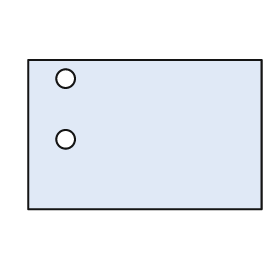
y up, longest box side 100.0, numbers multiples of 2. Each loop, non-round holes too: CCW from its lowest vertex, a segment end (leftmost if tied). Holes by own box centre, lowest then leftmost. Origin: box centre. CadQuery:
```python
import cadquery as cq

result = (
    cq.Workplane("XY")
    .moveTo(-50.0, -32.0)
    .lineTo(50.0, -32.0)
    .lineTo(50.0, 32.0)
    .lineTo(-50.0, 32.0)
    .close()
    .moveTo(-34.0, -2.0)
    .circle(4.0)
    .moveTo(-34.0, 24.0)
    .circle(4.0)
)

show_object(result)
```